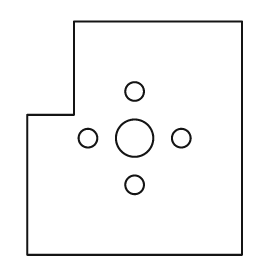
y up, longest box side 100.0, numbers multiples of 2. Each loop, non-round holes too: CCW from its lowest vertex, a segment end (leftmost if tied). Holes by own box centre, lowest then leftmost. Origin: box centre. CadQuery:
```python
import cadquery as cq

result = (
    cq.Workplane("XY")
    .moveTo(-46.0, -50.0)
    .lineTo(46.0, -50.0)
    .lineTo(46.0, 50.0)
    .lineTo(-26.0, 50.0)
    .lineTo(-26.0, 10.0)
    .lineTo(-46.0, 10.0)
    .close()
    .moveTo(0.0, -20.0)
    .circle(4.0)
    .moveTo(-20.0, 0.0)
    .circle(4.0)
    .moveTo(0.0, 0.0)
    .circle(8.0)
    .moveTo(20.0, 0.0)
    .circle(4.0)
    .moveTo(0.0, 20.0)
    .circle(4.0)
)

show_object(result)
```